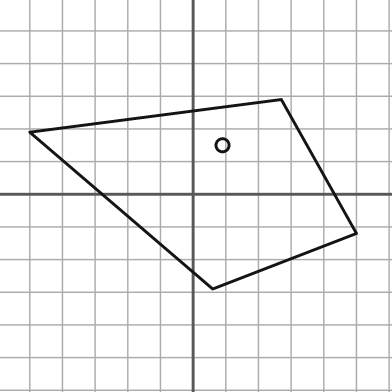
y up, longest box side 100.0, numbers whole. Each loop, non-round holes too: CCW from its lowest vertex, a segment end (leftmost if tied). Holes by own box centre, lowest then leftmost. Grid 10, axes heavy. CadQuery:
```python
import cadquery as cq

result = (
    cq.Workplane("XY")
    .moveTo(6.0, -29.0)
    .lineTo(50.0, -12.0)
    .lineTo(27.0, 29.0)
    .lineTo(-50.0, 19.0)
    .close()
    .moveTo(9.0, 15.0)
    .circle(2.0)
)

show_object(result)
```